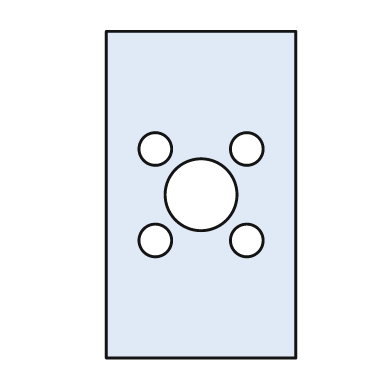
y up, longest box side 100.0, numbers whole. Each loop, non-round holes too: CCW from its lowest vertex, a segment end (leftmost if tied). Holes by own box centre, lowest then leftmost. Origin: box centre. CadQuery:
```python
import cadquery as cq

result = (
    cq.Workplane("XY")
    .moveTo(-29.0, -50.0)
    .lineTo(29.0, -50.0)
    .lineTo(29.0, 50.0)
    .lineTo(-29.0, 50.0)
    .close()
    .moveTo(-14.0, -14.0)
    .circle(5.0)
    .moveTo(14.0, -14.0)
    .circle(5.0)
    .moveTo(0.0, 0.0)
    .circle(11.0)
    .moveTo(-14.0, 14.0)
    .circle(5.0)
    .moveTo(14.0, 14.0)
    .circle(5.0)
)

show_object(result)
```